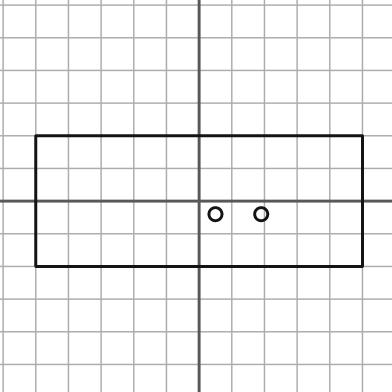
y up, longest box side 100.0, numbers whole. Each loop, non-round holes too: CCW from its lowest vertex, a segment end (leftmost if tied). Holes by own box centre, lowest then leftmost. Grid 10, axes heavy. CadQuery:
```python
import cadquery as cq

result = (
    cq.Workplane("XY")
    .moveTo(-50.0, -20.0)
    .lineTo(50.0, -20.0)
    .lineTo(50.0, 20.0)
    .lineTo(-50.0, 20.0)
    .close()
    .moveTo(5.0, -4.0)
    .circle(2.0)
    .moveTo(19.0, -4.0)
    .circle(2.0)
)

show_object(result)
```